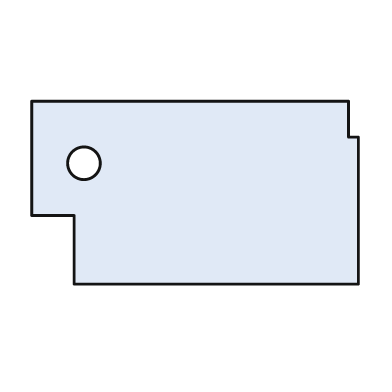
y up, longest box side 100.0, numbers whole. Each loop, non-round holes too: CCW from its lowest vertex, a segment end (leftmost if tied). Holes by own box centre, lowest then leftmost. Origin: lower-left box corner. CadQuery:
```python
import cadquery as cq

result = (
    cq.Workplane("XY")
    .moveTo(13.0, 0.0)
    .lineTo(100.0, 0.0)
    .lineTo(100.0, 45.0)
    .lineTo(97.0, 45.0)
    .lineTo(97.0, 56.0)
    .lineTo(0.0, 56.0)
    .lineTo(0.0, 21.0)
    .lineTo(13.0, 21.0)
    .close()
    .moveTo(16.0, 37.0)
    .circle(5.0)
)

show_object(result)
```